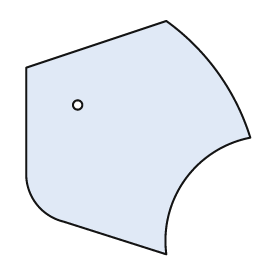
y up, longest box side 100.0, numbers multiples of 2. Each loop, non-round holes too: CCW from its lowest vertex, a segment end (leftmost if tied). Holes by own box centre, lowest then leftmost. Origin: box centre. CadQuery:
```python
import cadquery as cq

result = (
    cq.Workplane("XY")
    .moveTo(12.0, -50.0)
    .threePointArc((20.0, -18.0), (48.0, 0.0))
    .threePointArc((34.0, 28.0), (12.0, 50.0))
    .lineTo(-48.0, 30.0)
    .lineTo(-48.0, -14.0)
    .threePointArc((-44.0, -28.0), (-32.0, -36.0))
    .close()
    .moveTo(-26.0, 14.0)
    .circle(2.0)
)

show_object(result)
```